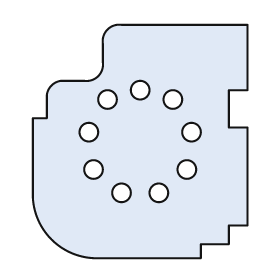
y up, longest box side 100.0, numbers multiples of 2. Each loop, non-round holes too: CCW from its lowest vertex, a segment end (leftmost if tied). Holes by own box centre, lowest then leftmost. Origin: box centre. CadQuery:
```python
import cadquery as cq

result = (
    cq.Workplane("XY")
    .moveTo(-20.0, -50.0)
    .lineTo(26.0, -50.0)
    .lineTo(26.0, -44.0)
    .lineTo(38.0, -44.0)
    .lineTo(38.0, -36.0)
    .lineTo(46.0, -36.0)
    .lineTo(46.0, 6.0)
    .lineTo(38.0, 6.0)
    .lineTo(38.0, 22.0)
    .lineTo(46.0, 22.0)
    .lineTo(46.0, 50.0)
    .lineTo(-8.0, 50.0)
    .threePointArc((-14.0, 48.0), (-16.0, 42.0))
    .lineTo(-16.0, 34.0)
    .threePointArc((-18.0, 28.0), (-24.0, 26.0))
    .lineTo(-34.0, 26.0)
    .threePointArc((-38.0, 24.0), (-40.0, 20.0))
    .lineTo(-40.0, 10.0)
    .lineTo(-46.0, 10.0)
    .lineTo(-46.0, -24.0)
    .threePointArc((-38.0, -42.0), (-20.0, -50.0))
    .close()
    .moveTo(-8.0, -22.0)
    .circle(4.0)
    .moveTo(8.0, -22.0)
    .circle(4.0)
    .moveTo(-20.0, -12.0)
    .circle(4.0)
    .moveTo(20.0, -12.0)
    .circle(4.0)
    .moveTo(-22.0, 4.0)
    .circle(4.0)
    .moveTo(22.0, 4.0)
    .circle(4.0)
    .moveTo(-14.0, 18.0)
    .circle(4.0)
    .moveTo(14.0, 18.0)
    .circle(4.0)
    .moveTo(0.0, 22.0)
    .circle(4.0)
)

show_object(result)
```